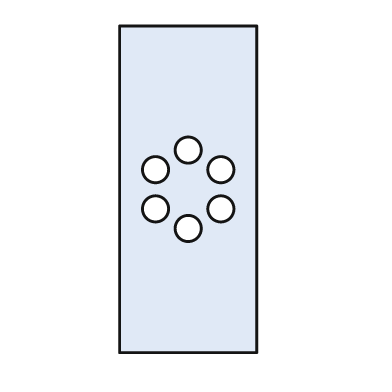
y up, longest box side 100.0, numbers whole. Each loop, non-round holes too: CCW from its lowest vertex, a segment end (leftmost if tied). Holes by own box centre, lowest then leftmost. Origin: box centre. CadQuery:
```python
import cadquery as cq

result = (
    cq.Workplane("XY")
    .moveTo(-21.0, -50.0)
    .lineTo(21.0, -50.0)
    .lineTo(21.0, 50.0)
    .lineTo(-21.0, 50.0)
    .close()
    .moveTo(0.0, -12.0)
    .circle(4.0)
    .moveTo(-10.0, -6.0)
    .circle(4.0)
    .moveTo(10.0, -6.0)
    .circle(4.0)
    .moveTo(-10.0, 6.0)
    .circle(4.0)
    .moveTo(10.0, 6.0)
    .circle(4.0)
    .moveTo(0.0, 12.0)
    .circle(4.0)
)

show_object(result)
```